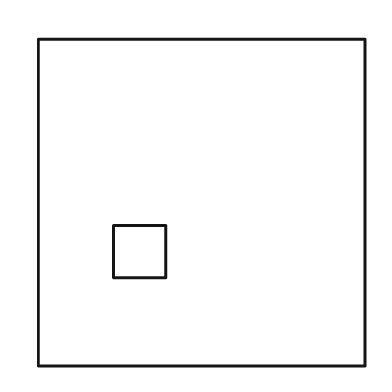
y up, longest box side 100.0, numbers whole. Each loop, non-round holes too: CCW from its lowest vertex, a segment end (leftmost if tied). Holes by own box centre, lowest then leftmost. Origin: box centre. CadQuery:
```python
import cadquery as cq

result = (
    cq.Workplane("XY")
    .moveTo(-50.0, -50.0)
    .lineTo(50.0, -50.0)
    .lineTo(50.0, 50.0)
    .lineTo(-50.0, 50.0)
    .close()
    .moveTo(-27.0, -23.0)
    .lineTo(-11.0, -23.0)
    .lineTo(-11.0, -7.0)
    .lineTo(-27.0, -7.0)
    .close()
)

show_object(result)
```